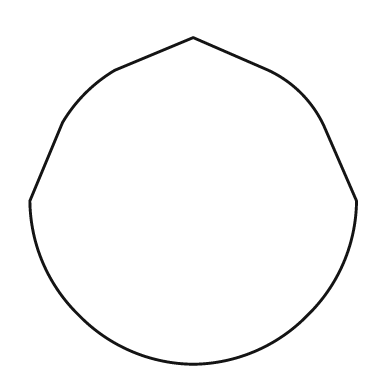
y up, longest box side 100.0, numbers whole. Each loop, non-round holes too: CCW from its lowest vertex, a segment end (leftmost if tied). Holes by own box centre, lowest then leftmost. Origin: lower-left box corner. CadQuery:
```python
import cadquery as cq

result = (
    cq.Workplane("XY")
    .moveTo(50.0, 0.0)
    .threePointArc((69.0, 4.0), (85.0, 15.0))
    .threePointArc((96.0, 31.0), (100.0, 50.0))
    .lineTo(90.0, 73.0)
    .threePointArc((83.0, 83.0), (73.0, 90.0))
    .lineTo(50.0, 100.0)
    .lineTo(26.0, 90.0)
    .threePointArc((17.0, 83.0), (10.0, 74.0))
    .lineTo(0.0, 50.0)
    .threePointArc((4.0, 31.0), (15.0, 15.0))
    .threePointArc((31.0, 4.0), (50.0, 0.0))
    .close()
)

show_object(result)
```